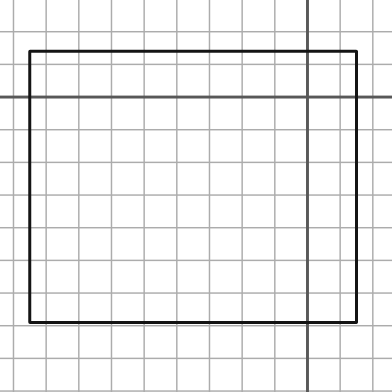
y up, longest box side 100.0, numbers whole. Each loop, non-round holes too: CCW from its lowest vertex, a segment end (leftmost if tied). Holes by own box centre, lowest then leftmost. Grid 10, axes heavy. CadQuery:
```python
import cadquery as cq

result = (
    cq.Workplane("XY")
    .moveTo(-85.0, -69.0)
    .lineTo(15.0, -69.0)
    .lineTo(15.0, 14.0)
    .lineTo(-85.0, 14.0)
    .close()
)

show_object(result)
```